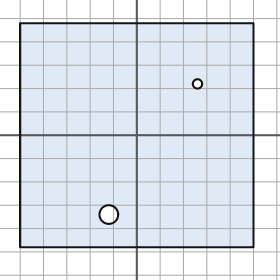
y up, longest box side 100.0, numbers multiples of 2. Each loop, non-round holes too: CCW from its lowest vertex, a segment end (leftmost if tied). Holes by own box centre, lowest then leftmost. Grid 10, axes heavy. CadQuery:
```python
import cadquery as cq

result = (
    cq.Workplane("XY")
    .moveTo(-50.0, -48.0)
    .lineTo(50.0, -48.0)
    .lineTo(50.0, 48.0)
    .lineTo(-50.0, 48.0)
    .close()
    .moveTo(-12.0, -34.0)
    .circle(4.0)
    .moveTo(26.0, 22.0)
    .circle(2.0)
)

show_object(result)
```